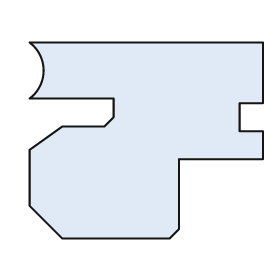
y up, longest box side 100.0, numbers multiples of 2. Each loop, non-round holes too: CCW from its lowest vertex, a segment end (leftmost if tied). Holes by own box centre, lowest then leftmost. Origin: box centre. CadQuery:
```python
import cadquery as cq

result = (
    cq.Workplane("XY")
    .moveTo(-36.0, -42.0)
    .lineTo(10.0, -42.0)
    .lineTo(14.0, -38.0)
    .lineTo(14.0, -8.0)
    .lineTo(50.0, -8.0)
    .lineTo(50.0, 4.0)
    .lineTo(40.0, 4.0)
    .lineTo(40.0, 16.0)
    .lineTo(50.0, 16.0)
    .lineTo(50.0, 42.0)
    .lineTo(-50.0, 42.0)
    .threePointArc((-44.0, 30.0), (-50.0, 18.0))
    .lineTo(-14.0, 18.0)
    .lineTo(-14.0, 10.0)
    .lineTo(-18.0, 6.0)
    .lineTo(-36.0, 6.0)
    .lineTo(-50.0, -4.0)
    .lineTo(-50.0, -28.0)
    .close()
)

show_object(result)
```